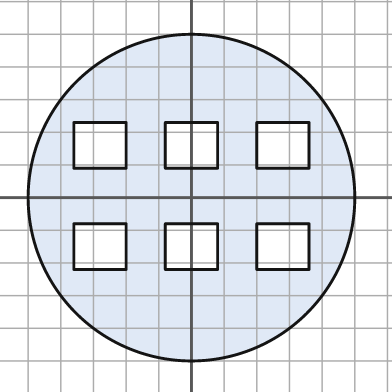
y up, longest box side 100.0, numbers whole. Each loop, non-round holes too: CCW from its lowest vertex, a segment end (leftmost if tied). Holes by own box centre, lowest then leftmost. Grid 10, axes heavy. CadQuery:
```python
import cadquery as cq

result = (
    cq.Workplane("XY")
    .moveTo(0.0, 0.0)
    .circle(50.0)
    .moveTo(-36.0, -22.0)
    .lineTo(-20.0, -22.0)
    .lineTo(-20.0, -8.0)
    .lineTo(-36.0, -8.0)
    .close()
    .moveTo(-8.0, -22.0)
    .lineTo(8.0, -22.0)
    .lineTo(8.0, -8.0)
    .lineTo(-8.0, -8.0)
    .close()
    .moveTo(20.0, -22.0)
    .lineTo(36.0, -22.0)
    .lineTo(36.0, -8.0)
    .lineTo(20.0, -8.0)
    .close()
    .moveTo(-36.0, 9.0)
    .lineTo(-20.0, 9.0)
    .lineTo(-20.0, 23.0)
    .lineTo(-36.0, 23.0)
    .close()
    .moveTo(-8.0, 9.0)
    .lineTo(8.0, 9.0)
    .lineTo(8.0, 23.0)
    .lineTo(-8.0, 23.0)
    .close()
    .moveTo(20.0, 9.0)
    .lineTo(36.0, 9.0)
    .lineTo(36.0, 23.0)
    .lineTo(20.0, 23.0)
    .close()
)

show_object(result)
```